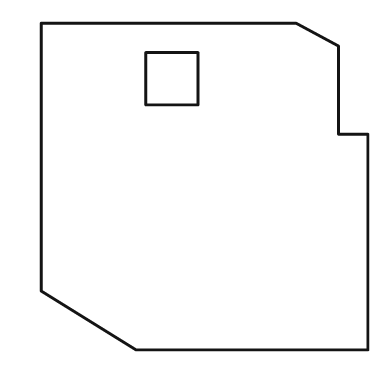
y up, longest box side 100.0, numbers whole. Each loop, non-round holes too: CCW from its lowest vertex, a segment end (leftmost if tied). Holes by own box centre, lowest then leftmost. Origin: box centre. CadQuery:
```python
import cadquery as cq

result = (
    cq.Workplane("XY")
    .moveTo(-21.0, -50.0)
    .lineTo(50.0, -50.0)
    .lineTo(50.0, 16.0)
    .lineTo(41.0, 16.0)
    .lineTo(41.0, 43.0)
    .lineTo(28.0, 50.0)
    .lineTo(-50.0, 50.0)
    .lineTo(-50.0, -32.0)
    .close()
    .moveTo(-18.0, 25.0)
    .lineTo(-2.0, 25.0)
    .lineTo(-2.0, 41.0)
    .lineTo(-18.0, 41.0)
    .close()
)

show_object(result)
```